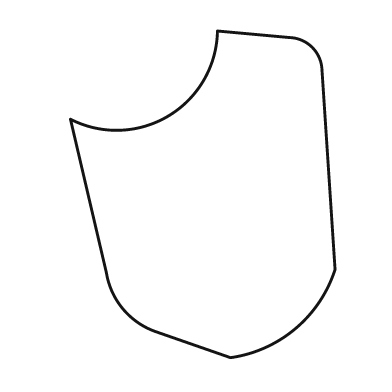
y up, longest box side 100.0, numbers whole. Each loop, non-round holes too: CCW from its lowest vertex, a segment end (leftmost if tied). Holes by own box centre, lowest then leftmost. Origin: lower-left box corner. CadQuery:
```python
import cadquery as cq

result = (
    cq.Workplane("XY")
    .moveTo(49.0, 0.0)
    .threePointArc((69.0, 9.0), (81.0, 27.0))
    .lineTo(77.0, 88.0)
    .threePointArc((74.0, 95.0), (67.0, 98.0))
    .lineTo(45.0, 100.0)
    .threePointArc((30.0, 74.0), (0.0, 73.0))
    .lineTo(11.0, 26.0)
    .threePointArc((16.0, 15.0), (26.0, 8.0))
    .close()
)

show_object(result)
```